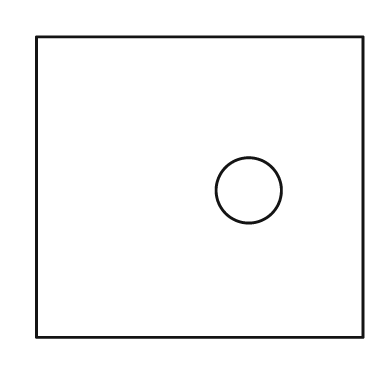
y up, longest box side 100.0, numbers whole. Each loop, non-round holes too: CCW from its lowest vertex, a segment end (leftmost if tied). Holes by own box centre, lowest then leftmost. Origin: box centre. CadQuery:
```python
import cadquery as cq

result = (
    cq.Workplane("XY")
    .moveTo(-50.0, -46.0)
    .lineTo(50.0, -46.0)
    .lineTo(50.0, 46.0)
    .lineTo(-50.0, 46.0)
    .close()
    .moveTo(15.0, -1.0)
    .circle(10.0)
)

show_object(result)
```